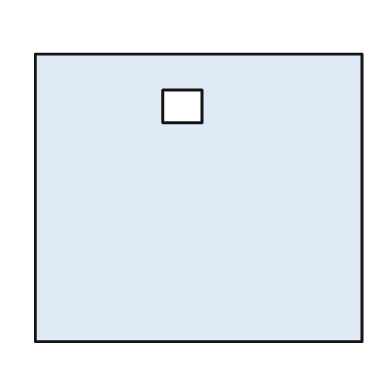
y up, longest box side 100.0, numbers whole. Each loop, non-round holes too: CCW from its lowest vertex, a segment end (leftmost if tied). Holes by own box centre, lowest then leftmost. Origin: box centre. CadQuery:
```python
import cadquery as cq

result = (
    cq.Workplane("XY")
    .moveTo(-50.0, -44.0)
    .lineTo(50.0, -44.0)
    .lineTo(50.0, 44.0)
    .lineTo(-50.0, 44.0)
    .close()
    .moveTo(-11.0, 23.0)
    .lineTo(1.0, 23.0)
    .lineTo(1.0, 33.0)
    .lineTo(-11.0, 33.0)
    .close()
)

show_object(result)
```